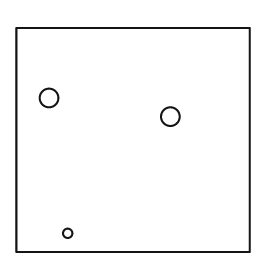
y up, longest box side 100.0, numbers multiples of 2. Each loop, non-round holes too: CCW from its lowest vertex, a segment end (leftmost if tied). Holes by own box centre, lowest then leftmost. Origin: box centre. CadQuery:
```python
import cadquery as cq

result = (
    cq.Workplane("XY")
    .moveTo(-50.0, -48.0)
    .lineTo(50.0, -48.0)
    .lineTo(50.0, 48.0)
    .lineTo(-50.0, 48.0)
    .close()
    .moveTo(-28.0, -40.0)
    .circle(2.0)
    .moveTo(16.0, 10.0)
    .circle(4.0)
    .moveTo(-36.0, 18.0)
    .circle(4.0)
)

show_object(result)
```